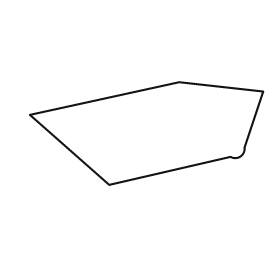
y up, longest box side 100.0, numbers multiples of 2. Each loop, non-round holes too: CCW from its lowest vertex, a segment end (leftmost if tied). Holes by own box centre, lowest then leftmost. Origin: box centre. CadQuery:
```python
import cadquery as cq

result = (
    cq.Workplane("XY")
    .moveTo(-16.0, -22.0)
    .lineTo(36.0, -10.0)
    .threePointArc((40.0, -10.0), (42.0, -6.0))
    .lineTo(50.0, 18.0)
    .lineTo(14.0, 22.0)
    .lineTo(-50.0, 8.0)
    .close()
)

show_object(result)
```